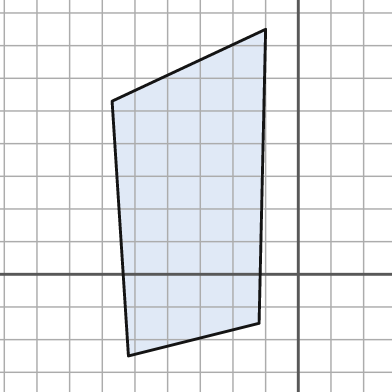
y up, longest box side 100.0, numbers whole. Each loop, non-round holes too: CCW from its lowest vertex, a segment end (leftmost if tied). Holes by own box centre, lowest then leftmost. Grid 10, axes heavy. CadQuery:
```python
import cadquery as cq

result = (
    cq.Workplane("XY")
    .moveTo(-52.0, -25.0)
    .lineTo(-12.0, -15.0)
    .lineTo(-10.0, 75.0)
    .lineTo(-57.0, 53.0)
    .close()
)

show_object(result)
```